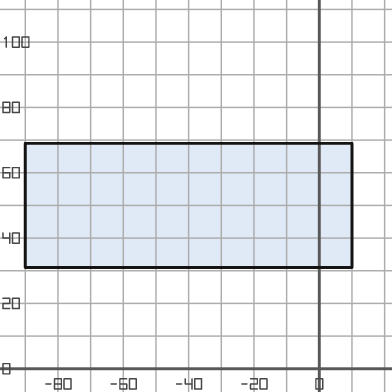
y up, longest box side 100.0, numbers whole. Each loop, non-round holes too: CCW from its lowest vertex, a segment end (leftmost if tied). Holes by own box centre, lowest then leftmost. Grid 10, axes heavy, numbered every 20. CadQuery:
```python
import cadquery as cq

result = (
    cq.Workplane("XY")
    .moveTo(-90.0, 31.0)
    .lineTo(10.0, 31.0)
    .lineTo(10.0, 69.0)
    .lineTo(-90.0, 69.0)
    .close()
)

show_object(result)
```